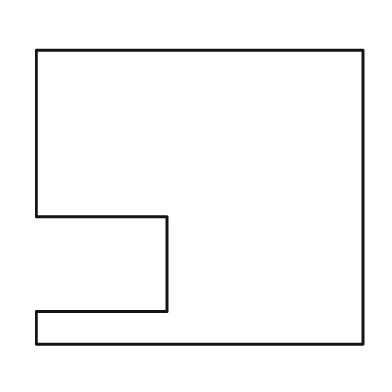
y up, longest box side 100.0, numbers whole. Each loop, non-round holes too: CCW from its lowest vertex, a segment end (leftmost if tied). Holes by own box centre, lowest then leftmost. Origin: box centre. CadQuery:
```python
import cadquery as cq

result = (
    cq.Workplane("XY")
    .moveTo(-50.0, -45.0)
    .lineTo(50.0, -45.0)
    .lineTo(50.0, 45.0)
    .lineTo(-50.0, 45.0)
    .lineTo(-50.0, -6.0)
    .lineTo(-10.0, -6.0)
    .lineTo(-10.0, -35.0)
    .lineTo(-50.0, -35.0)
    .close()
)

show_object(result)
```